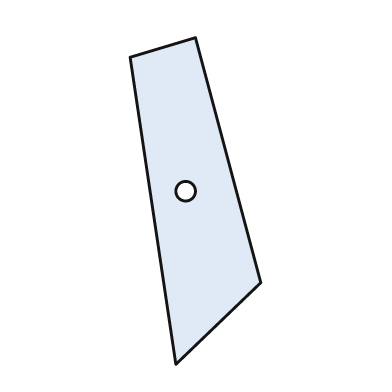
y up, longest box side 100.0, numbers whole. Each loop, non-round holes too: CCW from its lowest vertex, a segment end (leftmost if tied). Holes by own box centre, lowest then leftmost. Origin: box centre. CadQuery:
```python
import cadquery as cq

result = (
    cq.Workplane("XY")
    .moveTo(-6.0, -50.0)
    .lineTo(20.0, -25.0)
    .lineTo(0.0, 50.0)
    .lineTo(-20.0, 44.0)
    .close()
    .moveTo(-3.0, 3.0)
    .circle(3.0)
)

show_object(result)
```